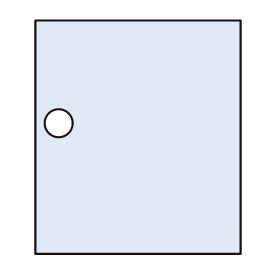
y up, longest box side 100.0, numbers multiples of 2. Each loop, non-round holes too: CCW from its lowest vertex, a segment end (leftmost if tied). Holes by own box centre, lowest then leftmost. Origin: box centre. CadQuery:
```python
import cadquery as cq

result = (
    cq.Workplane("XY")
    .moveTo(-44.0, -50.0)
    .lineTo(44.0, -50.0)
    .lineTo(44.0, 50.0)
    .lineTo(-44.0, 50.0)
    .close()
    .moveTo(-34.0, 6.0)
    .circle(6.0)
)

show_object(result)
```